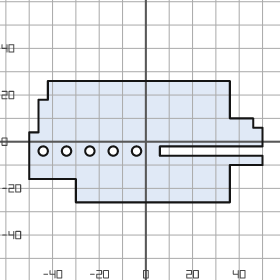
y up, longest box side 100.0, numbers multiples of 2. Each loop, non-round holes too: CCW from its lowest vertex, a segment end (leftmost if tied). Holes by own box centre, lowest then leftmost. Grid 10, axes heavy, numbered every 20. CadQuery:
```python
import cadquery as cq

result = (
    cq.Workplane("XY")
    .moveTo(-30.0, -26.0)
    .lineTo(36.0, -26.0)
    .lineTo(36.0, -10.0)
    .lineTo(50.0, -10.0)
    .lineTo(50.0, -6.0)
    .lineTo(6.0, -6.0)
    .lineTo(6.0, -2.0)
    .lineTo(50.0, -2.0)
    .lineTo(50.0, 6.0)
    .lineTo(46.0, 6.0)
    .lineTo(46.0, 10.0)
    .lineTo(36.0, 10.0)
    .lineTo(36.0, 26.0)
    .lineTo(-42.0, 26.0)
    .lineTo(-42.0, 18.0)
    .lineTo(-46.0, 18.0)
    .lineTo(-46.0, 4.0)
    .lineTo(-50.0, 4.0)
    .lineTo(-50.0, -16.0)
    .lineTo(-30.0, -16.0)
    .close()
    .moveTo(-44.0, -4.0)
    .circle(2.0)
    .moveTo(-34.0, -4.0)
    .circle(2.0)
    .moveTo(-24.0, -4.0)
    .circle(2.0)
    .moveTo(-14.0, -4.0)
    .circle(2.0)
    .moveTo(-4.0, -4.0)
    .circle(2.0)
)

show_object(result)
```